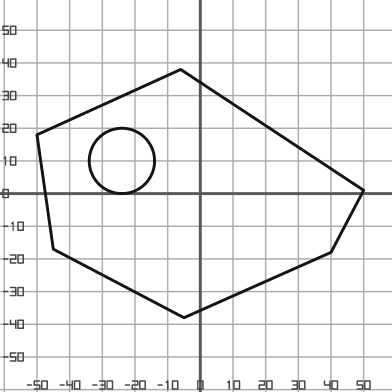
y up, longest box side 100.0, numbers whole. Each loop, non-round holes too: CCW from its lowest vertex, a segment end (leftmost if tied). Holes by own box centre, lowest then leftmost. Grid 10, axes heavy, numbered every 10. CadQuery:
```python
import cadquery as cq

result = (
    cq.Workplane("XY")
    .moveTo(-5.0, -38.0)
    .lineTo(40.0, -18.0)
    .lineTo(50.0, 1.0)
    .lineTo(-6.0, 38.0)
    .lineTo(-50.0, 18.0)
    .lineTo(-45.0, -17.0)
    .close()
    .moveTo(-24.0, 10.0)
    .circle(10.0)
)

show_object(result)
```